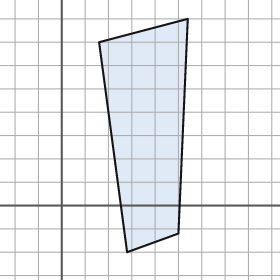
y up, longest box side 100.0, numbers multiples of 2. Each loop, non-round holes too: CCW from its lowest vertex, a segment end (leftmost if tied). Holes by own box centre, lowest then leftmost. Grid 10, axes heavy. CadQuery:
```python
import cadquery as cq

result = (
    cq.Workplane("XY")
    .moveTo(28.0, -20.0)
    .lineTo(50.0, -12.0)
    .lineTo(54.0, 80.0)
    .lineTo(16.0, 70.0)
    .close()
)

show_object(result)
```